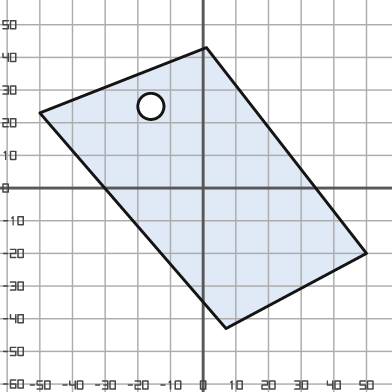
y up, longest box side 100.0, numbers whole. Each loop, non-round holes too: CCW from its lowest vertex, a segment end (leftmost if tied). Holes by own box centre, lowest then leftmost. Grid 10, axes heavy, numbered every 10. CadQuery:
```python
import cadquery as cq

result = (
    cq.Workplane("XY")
    .moveTo(7.0, -43.0)
    .lineTo(50.0, -20.0)
    .lineTo(1.0, 43.0)
    .lineTo(-50.0, 23.0)
    .close()
    .moveTo(-16.0, 25.0)
    .circle(4.0)
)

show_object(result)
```